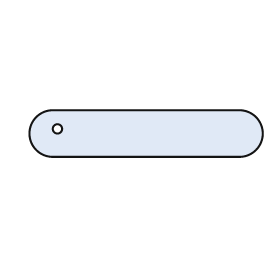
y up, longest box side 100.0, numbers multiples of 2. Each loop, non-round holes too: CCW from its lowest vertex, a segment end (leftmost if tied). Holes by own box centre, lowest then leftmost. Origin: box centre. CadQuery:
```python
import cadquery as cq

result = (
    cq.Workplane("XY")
    .moveTo(-40.0, -10.0)
    .lineTo(40.0, -10.0)
    .threePointArc((50.0, 0.0), (40.0, 10.0))
    .lineTo(-40.0, 10.0)
    .threePointArc((-50.0, 0.0), (-40.0, -10.0))
    .close()
    .moveTo(-38.0, 2.0)
    .circle(2.0)
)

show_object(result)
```